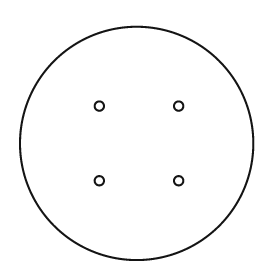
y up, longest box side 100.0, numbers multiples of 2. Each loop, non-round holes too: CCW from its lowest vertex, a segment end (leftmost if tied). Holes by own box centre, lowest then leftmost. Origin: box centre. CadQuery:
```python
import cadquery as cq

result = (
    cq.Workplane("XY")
    .moveTo(0.0, 0.0)
    .circle(50.0)
    .moveTo(-16.0, -16.0)
    .circle(2.0)
    .moveTo(18.0, -16.0)
    .circle(2.0)
    .moveTo(-16.0, 16.0)
    .circle(2.0)
    .moveTo(18.0, 16.0)
    .circle(2.0)
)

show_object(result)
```